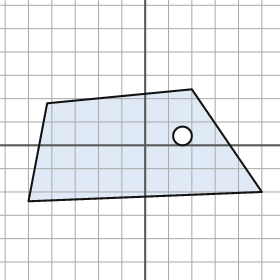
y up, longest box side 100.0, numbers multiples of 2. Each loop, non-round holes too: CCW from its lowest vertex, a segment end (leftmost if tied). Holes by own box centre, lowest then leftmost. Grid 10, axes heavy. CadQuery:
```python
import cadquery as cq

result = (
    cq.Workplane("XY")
    .moveTo(-50.0, -24.0)
    .lineTo(50.0, -20.0)
    .lineTo(20.0, 24.0)
    .lineTo(-42.0, 18.0)
    .close()
    .moveTo(16.0, 4.0)
    .circle(4.0)
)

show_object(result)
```